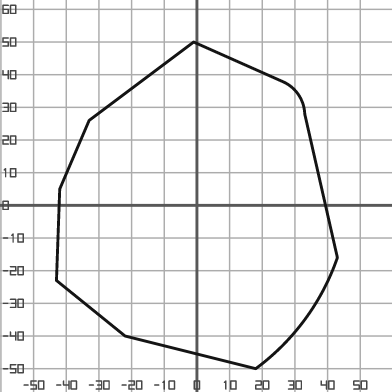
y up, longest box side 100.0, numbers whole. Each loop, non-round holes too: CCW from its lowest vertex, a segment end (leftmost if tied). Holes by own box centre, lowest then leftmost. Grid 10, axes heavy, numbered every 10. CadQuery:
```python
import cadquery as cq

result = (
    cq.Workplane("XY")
    .moveTo(18.0, -50.0)
    .threePointArc((33.0, -35.0), (43.0, -16.0))
    .lineTo(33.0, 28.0)
    .threePointArc((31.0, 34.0), (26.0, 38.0))
    .lineTo(-1.0, 50.0)
    .lineTo(-33.0, 26.0)
    .lineTo(-42.0, 5.0)
    .lineTo(-43.0, -23.0)
    .lineTo(-22.0, -40.0)
    .close()
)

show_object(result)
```